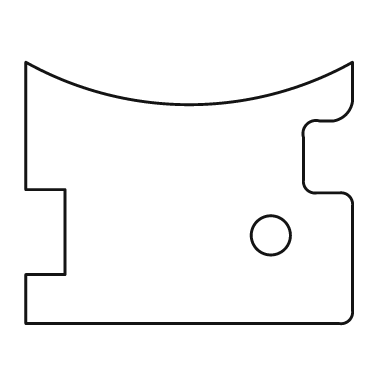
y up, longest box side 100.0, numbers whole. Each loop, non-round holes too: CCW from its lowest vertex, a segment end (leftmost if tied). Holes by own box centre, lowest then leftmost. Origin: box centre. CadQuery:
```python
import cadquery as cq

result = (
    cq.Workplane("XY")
    .moveTo(-50.0, -40.0)
    .lineTo(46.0, -40.0)
    .threePointArc((49.0, -39.0), (50.0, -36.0))
    .lineTo(50.0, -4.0)
    .threePointArc((49.0, -1.0), (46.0, 0.0))
    .lineTo(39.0, 0.0)
    .threePointArc((36.0, 1.0), (35.0, 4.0))
    .lineTo(35.0, 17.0)
    .threePointArc((36.0, 21.0), (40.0, 22.0))
    .lineTo(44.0, 22.0)
    .threePointArc((48.0, 24.0), (50.0, 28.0))
    .lineTo(50.0, 40.0)
    .threePointArc((0.0, 27.0), (-50.0, 40.0))
    .lineTo(-50.0, 1.0)
    .lineTo(-38.0, 1.0)
    .lineTo(-38.0, -25.0)
    .lineTo(-50.0, -25.0)
    .close()
    .moveTo(25.0, -13.0)
    .circle(6.0)
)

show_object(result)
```